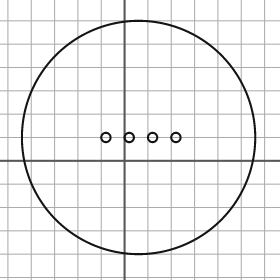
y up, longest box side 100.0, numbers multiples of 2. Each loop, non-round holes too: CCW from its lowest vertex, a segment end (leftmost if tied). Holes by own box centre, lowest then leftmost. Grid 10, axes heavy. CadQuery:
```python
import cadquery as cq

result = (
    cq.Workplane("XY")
    .moveTo(6.0, 10.0)
    .circle(50.0)
    .moveTo(-8.0, 10.0)
    .circle(2.0)
    .moveTo(2.0, 10.0)
    .circle(2.0)
    .moveTo(12.0, 10.0)
    .circle(2.0)
    .moveTo(22.0, 10.0)
    .circle(2.0)
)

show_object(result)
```